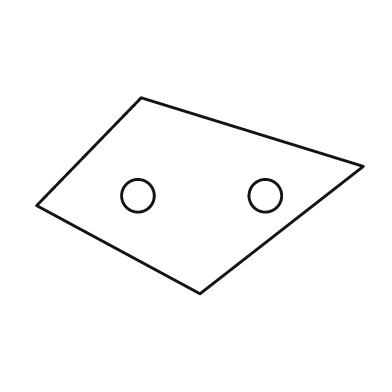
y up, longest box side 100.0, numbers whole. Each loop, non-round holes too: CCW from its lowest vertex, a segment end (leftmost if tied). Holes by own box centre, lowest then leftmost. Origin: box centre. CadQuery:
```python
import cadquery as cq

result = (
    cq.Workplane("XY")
    .moveTo(0.0, -30.0)
    .lineTo(50.0, 9.0)
    .lineTo(-18.0, 30.0)
    .lineTo(-50.0, -3.0)
    .close()
    .moveTo(-19.0, 0.0)
    .circle(5.0)
    .moveTo(20.0, 0.0)
    .circle(5.0)
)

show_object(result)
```